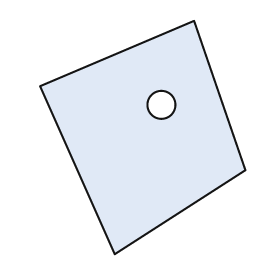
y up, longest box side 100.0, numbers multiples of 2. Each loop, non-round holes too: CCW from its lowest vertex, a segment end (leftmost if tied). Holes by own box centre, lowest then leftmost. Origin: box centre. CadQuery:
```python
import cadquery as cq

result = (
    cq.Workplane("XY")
    .moveTo(-12.0, -50.0)
    .lineTo(44.0, -14.0)
    .lineTo(22.0, 50.0)
    .lineTo(-44.0, 22.0)
    .close()
    .moveTo(8.0, 14.0)
    .circle(6.0)
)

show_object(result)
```